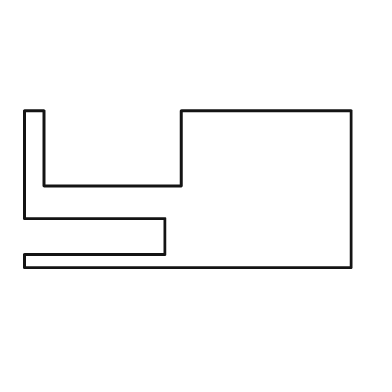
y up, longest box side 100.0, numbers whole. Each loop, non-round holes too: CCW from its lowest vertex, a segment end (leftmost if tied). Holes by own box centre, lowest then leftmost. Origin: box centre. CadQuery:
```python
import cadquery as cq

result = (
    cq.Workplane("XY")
    .moveTo(-50.0, -24.0)
    .lineTo(50.0, -24.0)
    .lineTo(50.0, 24.0)
    .lineTo(-2.0, 24.0)
    .lineTo(-2.0, 1.0)
    .lineTo(-44.0, 1.0)
    .lineTo(-44.0, 24.0)
    .lineTo(-50.0, 24.0)
    .lineTo(-50.0, -9.0)
    .lineTo(-7.0, -9.0)
    .lineTo(-7.0, -20.0)
    .lineTo(-50.0, -20.0)
    .close()
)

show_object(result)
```